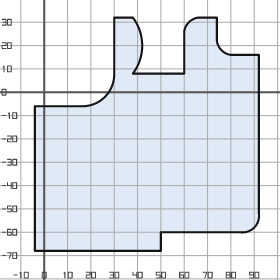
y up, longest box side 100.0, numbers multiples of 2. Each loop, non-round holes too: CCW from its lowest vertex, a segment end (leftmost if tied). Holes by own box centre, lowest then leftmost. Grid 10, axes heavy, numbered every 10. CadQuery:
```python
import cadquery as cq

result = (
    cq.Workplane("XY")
    .moveTo(-4.0, -68.0)
    .lineTo(50.0, -68.0)
    .lineTo(50.0, -60.0)
    .lineTo(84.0, -60.0)
    .threePointArc((90.0, -58.0), (92.0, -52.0))
    .lineTo(92.0, 16.0)
    .lineTo(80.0, 16.0)
    .threePointArc((76.0, 18.0), (74.0, 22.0))
    .lineTo(74.0, 32.0)
    .lineTo(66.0, 32.0)
    .threePointArc((62.0, 30.0), (60.0, 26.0))
    .lineTo(60.0, 8.0)
    .lineTo(38.0, 8.0)
    .threePointArc((42.0, 20.0), (38.0, 32.0))
    .lineTo(30.0, 32.0)
    .lineTo(30.0, 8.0)
    .threePointArc((26.0, -2.0), (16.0, -6.0))
    .lineTo(-4.0, -6.0)
    .close()
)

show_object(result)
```